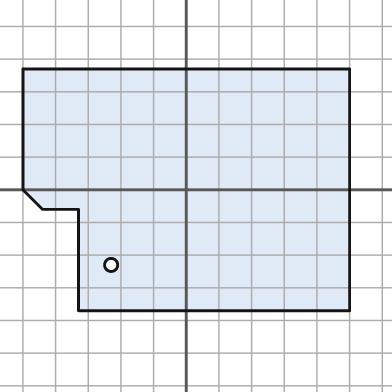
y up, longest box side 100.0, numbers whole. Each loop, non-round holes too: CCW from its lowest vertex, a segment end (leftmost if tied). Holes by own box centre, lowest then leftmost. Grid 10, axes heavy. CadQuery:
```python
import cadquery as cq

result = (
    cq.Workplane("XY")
    .moveTo(-33.0, -37.0)
    .lineTo(50.0, -37.0)
    .lineTo(50.0, 37.0)
    .lineTo(-50.0, 37.0)
    .lineTo(-50.0, 0.0)
    .lineTo(-44.0, -6.0)
    .lineTo(-33.0, -6.0)
    .close()
    .moveTo(-23.0, -23.0)
    .circle(2.0)
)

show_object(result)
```